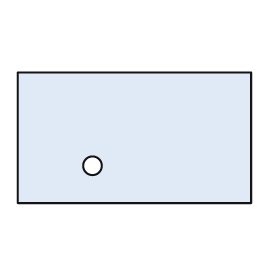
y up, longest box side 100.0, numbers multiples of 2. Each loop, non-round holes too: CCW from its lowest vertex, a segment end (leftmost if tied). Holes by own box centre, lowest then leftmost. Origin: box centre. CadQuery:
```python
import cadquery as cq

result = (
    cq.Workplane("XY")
    .moveTo(-50.0, -28.0)
    .lineTo(50.0, -28.0)
    .lineTo(50.0, 28.0)
    .lineTo(-50.0, 28.0)
    .close()
    .moveTo(-18.0, -12.0)
    .circle(4.0)
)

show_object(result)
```